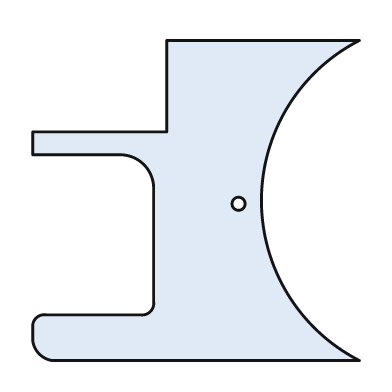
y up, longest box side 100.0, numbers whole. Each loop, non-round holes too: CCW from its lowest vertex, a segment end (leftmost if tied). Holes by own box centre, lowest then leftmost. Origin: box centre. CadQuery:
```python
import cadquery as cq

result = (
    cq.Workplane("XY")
    .moveTo(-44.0, -49.0)
    .lineTo(50.0, -49.0)
    .threePointArc((20.0, 0.0), (50.0, 49.0))
    .lineTo(-9.0, 49.0)
    .lineTo(-9.0, 21.0)
    .lineTo(-50.0, 21.0)
    .lineTo(-50.0, 14.0)
    .lineTo(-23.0, 14.0)
    .threePointArc((-16.0, 11.0), (-13.0, 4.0))
    .lineTo(-13.0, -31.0)
    .threePointArc((-14.0, -34.0), (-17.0, -35.0))
    .lineTo(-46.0, -35.0)
    .threePointArc((-49.0, -36.0), (-50.0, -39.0))
    .lineTo(-50.0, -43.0)
    .threePointArc((-48.0, -47.0), (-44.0, -49.0))
    .close()
    .moveTo(13.0, -1.0)
    .circle(2.0)
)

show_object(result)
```